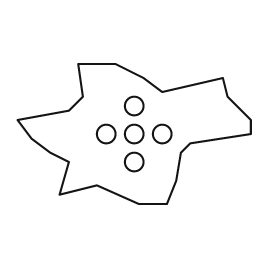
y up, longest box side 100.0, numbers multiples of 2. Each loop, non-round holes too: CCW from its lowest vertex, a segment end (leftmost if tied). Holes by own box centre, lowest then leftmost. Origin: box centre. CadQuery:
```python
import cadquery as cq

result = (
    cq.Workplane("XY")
    .moveTo(2.0, -30.0)
    .lineTo(14.0, -30.0)
    .lineTo(18.0, -20.0)
    .lineTo(20.0, -8.0)
    .lineTo(24.0, -4.0)
    .lineTo(50.0, 0.0)
    .lineTo(50.0, 6.0)
    .lineTo(40.0, 16.0)
    .lineTo(38.0, 24.0)
    .lineTo(12.0, 18.0)
    .lineTo(4.0, 24.0)
    .lineTo(-8.0, 30.0)
    .lineTo(-24.0, 30.0)
    .lineTo(-22.0, 16.0)
    .lineTo(-28.0, 10.0)
    .lineTo(-50.0, 6.0)
    .lineTo(-44.0, -2.0)
    .lineTo(-36.0, -8.0)
    .lineTo(-28.0, -12.0)
    .lineTo(-32.0, -26.0)
    .lineTo(-16.0, -22.0)
    .close()
    .moveTo(0.0, -12.0)
    .circle(4.0)
    .moveTo(-12.0, 0.0)
    .circle(4.0)
    .moveTo(0.0, 0.0)
    .circle(4.0)
    .moveTo(12.0, 0.0)
    .circle(4.0)
    .moveTo(0.0, 12.0)
    .circle(4.0)
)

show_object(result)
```